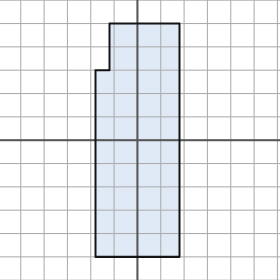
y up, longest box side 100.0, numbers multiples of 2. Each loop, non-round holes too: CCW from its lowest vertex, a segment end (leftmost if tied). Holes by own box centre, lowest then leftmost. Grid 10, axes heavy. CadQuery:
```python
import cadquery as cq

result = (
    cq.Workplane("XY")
    .moveTo(-18.0, -50.0)
    .lineTo(18.0, -50.0)
    .lineTo(18.0, 50.0)
    .lineTo(-12.0, 50.0)
    .lineTo(-12.0, 30.0)
    .lineTo(-18.0, 30.0)
    .close()
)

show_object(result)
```